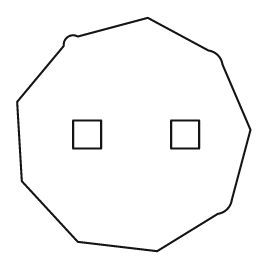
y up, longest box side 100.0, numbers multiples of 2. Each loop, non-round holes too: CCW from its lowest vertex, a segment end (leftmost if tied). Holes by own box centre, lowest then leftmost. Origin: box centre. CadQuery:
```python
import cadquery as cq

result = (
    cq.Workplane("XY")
    .moveTo(10.0, -50.0)
    .lineTo(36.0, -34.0)
    .threePointArc((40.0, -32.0), (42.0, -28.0))
    .lineTo(50.0, 2.0)
    .lineTo(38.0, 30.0)
    .threePointArc((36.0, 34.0), (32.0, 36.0))
    .lineTo(6.0, 50.0)
    .lineTo(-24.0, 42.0)
    .threePointArc((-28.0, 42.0), (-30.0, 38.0))
    .lineTo(-50.0, 14.0)
    .lineTo(-48.0, -20.0)
    .lineTo(-24.0, -46.0)
    .close()
    .moveTo(-26.0, -6.0)
    .lineTo(-14.0, -6.0)
    .lineTo(-14.0, 6.0)
    .lineTo(-26.0, 6.0)
    .close()
    .moveTo(16.0, -6.0)
    .lineTo(28.0, -6.0)
    .lineTo(28.0, 6.0)
    .lineTo(16.0, 6.0)
    .close()
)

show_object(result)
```